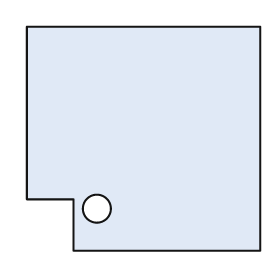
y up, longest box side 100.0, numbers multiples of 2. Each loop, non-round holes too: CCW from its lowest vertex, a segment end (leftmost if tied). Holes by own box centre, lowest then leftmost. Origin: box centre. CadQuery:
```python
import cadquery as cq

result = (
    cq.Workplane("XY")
    .moveTo(-30.0, -48.0)
    .lineTo(50.0, -48.0)
    .lineTo(50.0, 48.0)
    .lineTo(-50.0, 48.0)
    .lineTo(-50.0, -26.0)
    .lineTo(-30.0, -26.0)
    .close()
    .moveTo(-20.0, -30.0)
    .circle(6.0)
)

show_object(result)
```